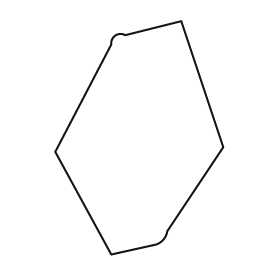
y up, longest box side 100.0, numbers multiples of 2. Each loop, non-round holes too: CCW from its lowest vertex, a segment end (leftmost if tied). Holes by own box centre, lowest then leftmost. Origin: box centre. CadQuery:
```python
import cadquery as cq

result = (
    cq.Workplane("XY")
    .moveTo(-12.0, -50.0)
    .lineTo(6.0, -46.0)
    .threePointArc((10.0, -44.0), (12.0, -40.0))
    .lineTo(36.0, -4.0)
    .lineTo(18.0, 50.0)
    .lineTo(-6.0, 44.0)
    .threePointArc((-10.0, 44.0), (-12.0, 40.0))
    .lineTo(-36.0, -6.0)
    .close()
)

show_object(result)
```